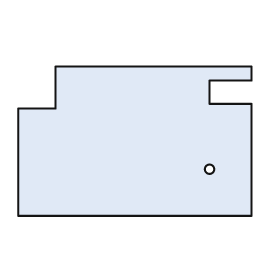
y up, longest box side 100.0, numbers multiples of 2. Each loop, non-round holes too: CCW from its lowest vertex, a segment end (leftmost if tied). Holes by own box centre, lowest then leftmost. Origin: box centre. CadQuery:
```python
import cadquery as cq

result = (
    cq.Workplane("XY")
    .moveTo(-50.0, -32.0)
    .lineTo(50.0, -32.0)
    .lineTo(50.0, 16.0)
    .lineTo(32.0, 16.0)
    .lineTo(32.0, 26.0)
    .lineTo(50.0, 26.0)
    .lineTo(50.0, 32.0)
    .lineTo(-34.0, 32.0)
    .lineTo(-34.0, 14.0)
    .lineTo(-50.0, 14.0)
    .close()
    .moveTo(32.0, -12.0)
    .circle(2.0)
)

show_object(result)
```